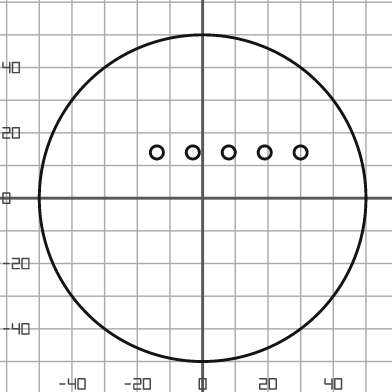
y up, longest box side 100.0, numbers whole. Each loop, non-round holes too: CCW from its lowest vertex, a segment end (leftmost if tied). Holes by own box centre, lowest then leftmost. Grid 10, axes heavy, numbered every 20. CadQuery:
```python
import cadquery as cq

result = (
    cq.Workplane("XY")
    .moveTo(0.0, 0.0)
    .circle(50.0)
    .moveTo(-14.0, 14.0)
    .circle(2.0)
    .moveTo(-3.0, 14.0)
    .circle(2.0)
    .moveTo(8.0, 14.0)
    .circle(2.0)
    .moveTo(19.0, 14.0)
    .circle(2.0)
    .moveTo(30.0, 14.0)
    .circle(2.0)
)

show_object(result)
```